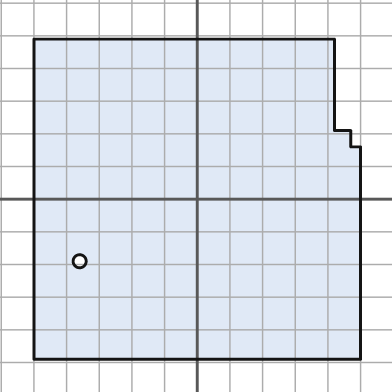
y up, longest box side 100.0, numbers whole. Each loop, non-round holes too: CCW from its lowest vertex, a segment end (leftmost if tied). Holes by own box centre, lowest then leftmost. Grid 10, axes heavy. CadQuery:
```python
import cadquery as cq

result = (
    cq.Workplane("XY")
    .moveTo(-50.0, -49.0)
    .lineTo(50.0, -49.0)
    .lineTo(50.0, 16.0)
    .lineTo(47.0, 16.0)
    .lineTo(47.0, 21.0)
    .lineTo(42.0, 21.0)
    .lineTo(42.0, 49.0)
    .lineTo(-50.0, 49.0)
    .close()
    .moveTo(-36.0, -19.0)
    .circle(2.0)
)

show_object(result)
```